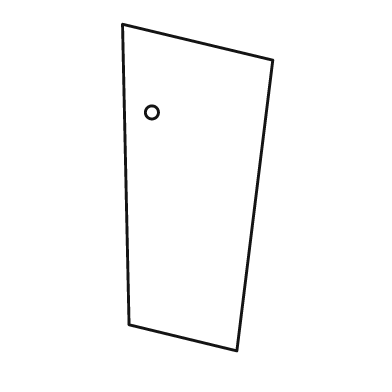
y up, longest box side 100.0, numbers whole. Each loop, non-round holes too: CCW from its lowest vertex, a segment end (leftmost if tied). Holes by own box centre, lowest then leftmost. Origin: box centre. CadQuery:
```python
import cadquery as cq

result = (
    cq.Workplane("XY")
    .moveTo(12.0, -50.0)
    .lineTo(23.0, 39.0)
    .lineTo(-23.0, 50.0)
    .lineTo(-21.0, -42.0)
    .close()
    .moveTo(-14.0, 23.0)
    .circle(2.0)
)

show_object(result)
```